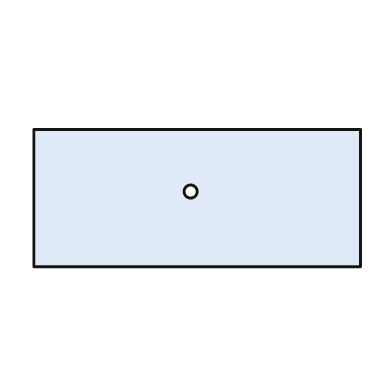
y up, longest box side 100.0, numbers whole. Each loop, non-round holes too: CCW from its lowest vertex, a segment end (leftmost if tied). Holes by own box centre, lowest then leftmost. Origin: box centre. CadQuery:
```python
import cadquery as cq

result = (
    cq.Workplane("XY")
    .moveTo(-50.0, -21.0)
    .lineTo(50.0, -21.0)
    .lineTo(50.0, 21.0)
    .lineTo(-50.0, 21.0)
    .close()
    .moveTo(-2.0, 2.0)
    .circle(2.0)
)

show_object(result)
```